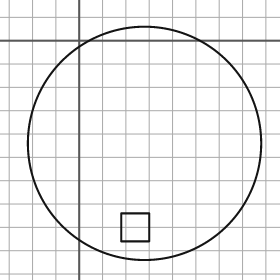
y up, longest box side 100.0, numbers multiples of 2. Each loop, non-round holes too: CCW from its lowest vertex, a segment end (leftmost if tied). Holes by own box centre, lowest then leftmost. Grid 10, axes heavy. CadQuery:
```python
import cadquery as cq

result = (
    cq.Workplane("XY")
    .moveTo(28.0, -44.0)
    .circle(50.0)
    .moveTo(18.0, -86.0)
    .lineTo(30.0, -86.0)
    .lineTo(30.0, -74.0)
    .lineTo(18.0, -74.0)
    .close()
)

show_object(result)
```